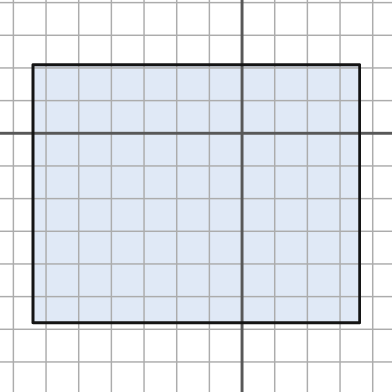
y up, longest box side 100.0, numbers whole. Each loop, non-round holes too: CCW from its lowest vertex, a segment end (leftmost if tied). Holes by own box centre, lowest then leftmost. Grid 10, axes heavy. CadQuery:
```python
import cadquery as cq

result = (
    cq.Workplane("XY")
    .moveTo(-64.0, -58.0)
    .lineTo(36.0, -58.0)
    .lineTo(36.0, 21.0)
    .lineTo(-64.0, 21.0)
    .close()
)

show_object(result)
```